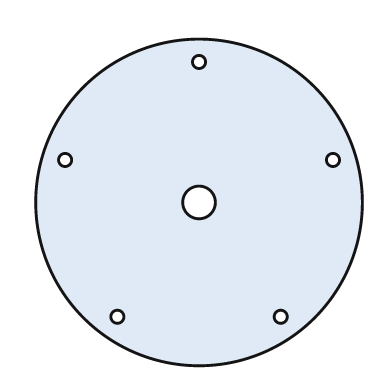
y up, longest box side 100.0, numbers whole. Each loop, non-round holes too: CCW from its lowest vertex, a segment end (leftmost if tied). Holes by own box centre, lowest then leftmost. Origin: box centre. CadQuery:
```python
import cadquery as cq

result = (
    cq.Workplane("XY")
    .moveTo(0.0, 0.0)
    .circle(50.0)
    .moveTo(-25.0, -35.0)
    .circle(2.0)
    .moveTo(25.0, -35.0)
    .circle(2.0)
    .moveTo(0.0, 0.0)
    .circle(5.0)
    .moveTo(-41.0, 13.0)
    .circle(2.0)
    .moveTo(41.0, 13.0)
    .circle(2.0)
    .moveTo(0.0, 43.0)
    .circle(2.0)
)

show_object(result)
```